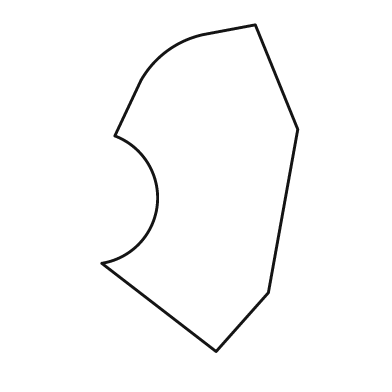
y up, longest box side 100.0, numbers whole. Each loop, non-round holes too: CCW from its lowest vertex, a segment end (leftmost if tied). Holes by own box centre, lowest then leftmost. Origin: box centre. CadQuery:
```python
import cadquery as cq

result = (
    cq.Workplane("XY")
    .moveTo(5.0, -50.0)
    .lineTo(21.0, -32.0)
    .lineTo(30.0, 18.0)
    .lineTo(17.0, 50.0)
    .lineTo(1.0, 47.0)
    .threePointArc((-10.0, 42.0), (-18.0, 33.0))
    .lineTo(-26.0, 16.0)
    .threePointArc((-13.0, -5.0), (-30.0, -23.0))
    .close()
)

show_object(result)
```